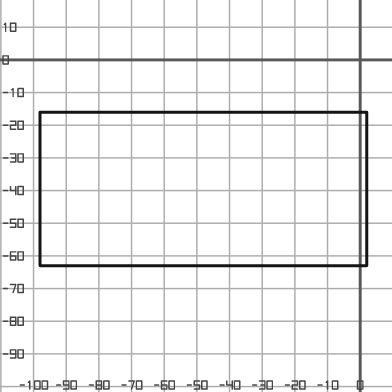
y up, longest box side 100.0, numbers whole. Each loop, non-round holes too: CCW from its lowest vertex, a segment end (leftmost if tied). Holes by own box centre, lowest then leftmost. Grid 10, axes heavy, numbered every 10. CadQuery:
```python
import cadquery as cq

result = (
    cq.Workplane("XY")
    .moveTo(-98.0, -63.0)
    .lineTo(2.0, -63.0)
    .lineTo(2.0, -16.0)
    .lineTo(-98.0, -16.0)
    .close()
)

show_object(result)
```